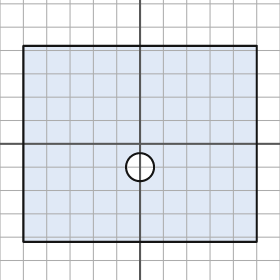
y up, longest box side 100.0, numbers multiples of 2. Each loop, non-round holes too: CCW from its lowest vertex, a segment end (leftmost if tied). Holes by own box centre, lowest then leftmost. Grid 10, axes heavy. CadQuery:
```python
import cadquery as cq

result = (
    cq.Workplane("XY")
    .moveTo(-50.0, -42.0)
    .lineTo(50.0, -42.0)
    .lineTo(50.0, 42.0)
    .lineTo(-50.0, 42.0)
    .close()
    .moveTo(0.0, -10.0)
    .circle(6.0)
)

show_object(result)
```